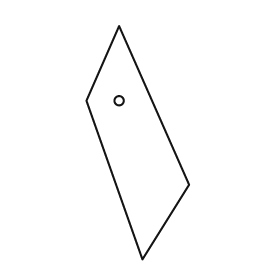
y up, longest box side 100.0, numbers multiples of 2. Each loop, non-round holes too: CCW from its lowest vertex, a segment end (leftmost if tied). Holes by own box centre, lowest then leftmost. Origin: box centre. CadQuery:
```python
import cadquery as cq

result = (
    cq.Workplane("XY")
    .moveTo(2.0, -50.0)
    .lineTo(22.0, -18.0)
    .lineTo(-8.0, 50.0)
    .lineTo(-22.0, 18.0)
    .close()
    .moveTo(-8.0, 18.0)
    .circle(2.0)
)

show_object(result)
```